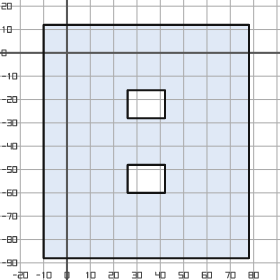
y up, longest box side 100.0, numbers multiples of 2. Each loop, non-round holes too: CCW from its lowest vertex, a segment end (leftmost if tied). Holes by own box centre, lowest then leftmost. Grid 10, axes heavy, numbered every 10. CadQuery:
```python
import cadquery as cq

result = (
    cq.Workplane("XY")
    .moveTo(-10.0, -88.0)
    .lineTo(78.0, -88.0)
    .lineTo(78.0, 12.0)
    .lineTo(-10.0, 12.0)
    .close()
    .moveTo(26.0, -60.0)
    .lineTo(42.0, -60.0)
    .lineTo(42.0, -48.0)
    .lineTo(26.0, -48.0)
    .close()
    .moveTo(26.0, -28.0)
    .lineTo(42.0, -28.0)
    .lineTo(42.0, -16.0)
    .lineTo(26.0, -16.0)
    .close()
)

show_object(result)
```